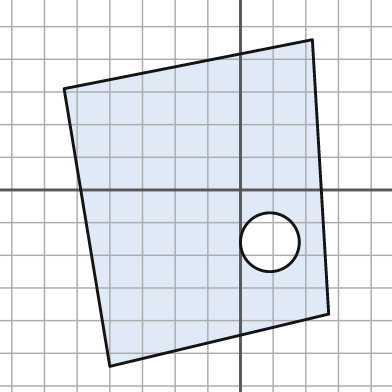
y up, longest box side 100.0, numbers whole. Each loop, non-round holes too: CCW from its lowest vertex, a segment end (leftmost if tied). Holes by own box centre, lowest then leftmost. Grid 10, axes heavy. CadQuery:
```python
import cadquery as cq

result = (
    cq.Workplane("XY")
    .moveTo(-40.0, -54.0)
    .lineTo(27.0, -38.0)
    .lineTo(22.0, 46.0)
    .lineTo(-54.0, 31.0)
    .close()
    .moveTo(9.0, -16.0)
    .circle(9.0)
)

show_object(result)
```